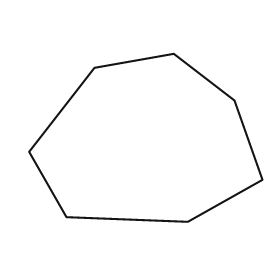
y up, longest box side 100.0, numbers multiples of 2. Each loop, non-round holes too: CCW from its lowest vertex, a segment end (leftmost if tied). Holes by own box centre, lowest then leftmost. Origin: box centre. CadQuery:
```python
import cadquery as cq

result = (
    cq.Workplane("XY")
    .moveTo(18.0, -36.0)
    .lineTo(50.0, -18.0)
    .lineTo(38.0, 16.0)
    .lineTo(12.0, 36.0)
    .lineTo(-22.0, 30.0)
    .lineTo(-50.0, -6.0)
    .lineTo(-34.0, -34.0)
    .close()
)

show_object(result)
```